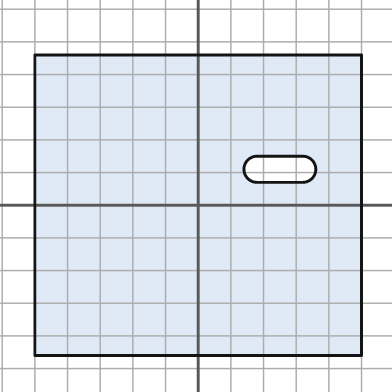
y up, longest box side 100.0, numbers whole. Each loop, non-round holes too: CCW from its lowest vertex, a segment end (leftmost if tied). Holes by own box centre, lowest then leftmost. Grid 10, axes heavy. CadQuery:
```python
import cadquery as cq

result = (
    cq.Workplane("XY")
    .moveTo(-50.0, -46.0)
    .lineTo(50.0, -46.0)
    .lineTo(50.0, 46.0)
    .lineTo(-50.0, 46.0)
    .close()
    .moveTo(18.0, 7.0)
    .lineTo(32.0, 7.0)
    .threePointArc((36.0, 11.0), (32.0, 15.0))
    .lineTo(18.0, 15.0)
    .threePointArc((14.0, 11.0), (18.0, 7.0))
    .close()
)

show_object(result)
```